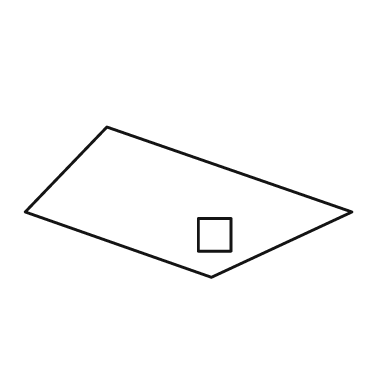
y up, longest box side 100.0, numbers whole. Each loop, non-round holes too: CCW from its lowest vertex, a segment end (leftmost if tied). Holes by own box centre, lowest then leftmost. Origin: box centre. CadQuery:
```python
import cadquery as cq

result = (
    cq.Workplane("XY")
    .moveTo(7.0, -23.0)
    .lineTo(50.0, -3.0)
    .lineTo(-25.0, 23.0)
    .lineTo(-50.0, -3.0)
    .close()
    .moveTo(3.0, -15.0)
    .lineTo(13.0, -15.0)
    .lineTo(13.0, -5.0)
    .lineTo(3.0, -5.0)
    .close()
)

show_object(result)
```